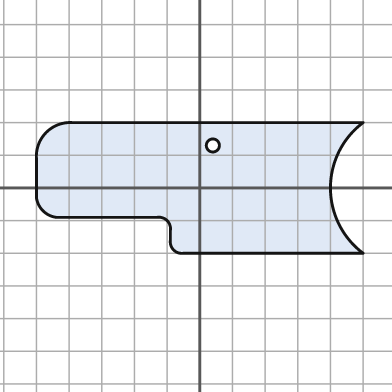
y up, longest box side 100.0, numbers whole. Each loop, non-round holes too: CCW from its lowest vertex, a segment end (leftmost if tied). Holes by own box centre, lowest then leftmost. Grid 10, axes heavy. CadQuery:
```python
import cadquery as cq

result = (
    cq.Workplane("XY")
    .moveTo(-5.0, -20.0)
    .lineTo(50.0, -20.0)
    .threePointArc((40.0, 0.0), (50.0, 20.0))
    .lineTo(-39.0, 20.0)
    .threePointArc((-47.0, 17.0), (-50.0, 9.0))
    .lineTo(-50.0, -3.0)
    .threePointArc((-48.0, -7.0), (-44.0, -9.0))
    .lineTo(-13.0, -9.0)
    .threePointArc((-10.0, -10.0), (-9.0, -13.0))
    .lineTo(-9.0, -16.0)
    .threePointArc((-8.0, -19.0), (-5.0, -20.0))
    .close()
    .moveTo(4.0, 13.0)
    .circle(2.0)
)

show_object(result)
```